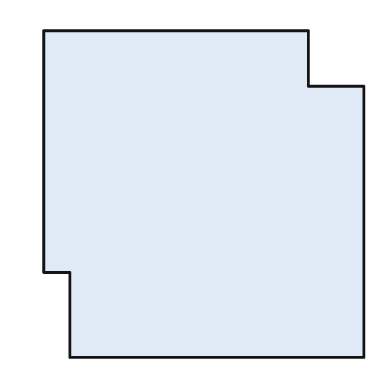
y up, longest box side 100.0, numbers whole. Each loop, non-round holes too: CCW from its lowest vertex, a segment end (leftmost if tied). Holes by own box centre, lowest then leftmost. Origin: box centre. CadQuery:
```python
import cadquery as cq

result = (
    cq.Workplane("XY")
    .moveTo(-41.0, -50.0)
    .lineTo(49.0, -50.0)
    .lineTo(49.0, 33.0)
    .lineTo(32.0, 33.0)
    .lineTo(32.0, 50.0)
    .lineTo(-49.0, 50.0)
    .lineTo(-49.0, -24.0)
    .lineTo(-41.0, -24.0)
    .close()
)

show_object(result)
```